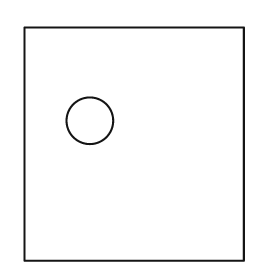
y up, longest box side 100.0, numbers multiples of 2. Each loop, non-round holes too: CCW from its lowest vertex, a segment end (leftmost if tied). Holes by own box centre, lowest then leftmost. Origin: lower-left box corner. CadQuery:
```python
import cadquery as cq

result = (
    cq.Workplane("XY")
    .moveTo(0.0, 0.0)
    .lineTo(94.0, 0.0)
    .lineTo(94.0, 100.0)
    .lineTo(0.0, 100.0)
    .close()
    .moveTo(28.0, 60.0)
    .circle(10.0)
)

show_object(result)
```